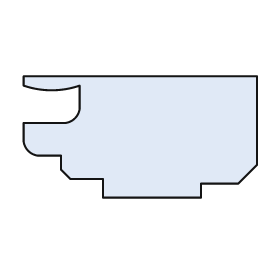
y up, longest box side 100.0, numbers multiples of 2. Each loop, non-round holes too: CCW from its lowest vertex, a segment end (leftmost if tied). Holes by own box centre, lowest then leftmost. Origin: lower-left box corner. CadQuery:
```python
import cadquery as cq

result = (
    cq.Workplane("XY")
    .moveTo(34.0, 0.0)
    .lineTo(76.0, 0.0)
    .lineTo(76.0, 6.0)
    .lineTo(92.0, 6.0)
    .lineTo(100.0, 14.0)
    .lineTo(100.0, 52.0)
    .lineTo(0.0, 52.0)
    .lineTo(0.0, 48.0)
    .threePointArc((12.0, 46.0), (24.0, 48.0))
    .lineTo(24.0, 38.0)
    .threePointArc((22.0, 34.0), (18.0, 32.0))
    .lineTo(0.0, 32.0)
    .lineTo(0.0, 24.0)
    .threePointArc((2.0, 20.0), (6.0, 18.0))
    .lineTo(16.0, 18.0)
    .lineTo(16.0, 12.0)
    .lineTo(20.0, 8.0)
    .lineTo(34.0, 8.0)
    .close()
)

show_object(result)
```